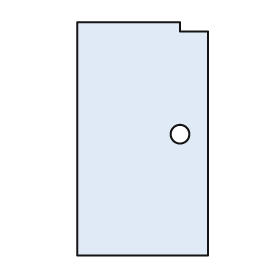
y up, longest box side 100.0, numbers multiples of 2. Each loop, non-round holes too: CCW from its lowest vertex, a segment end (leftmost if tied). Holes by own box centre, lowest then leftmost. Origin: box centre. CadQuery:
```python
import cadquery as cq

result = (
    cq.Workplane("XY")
    .moveTo(-28.0, -50.0)
    .lineTo(28.0, -50.0)
    .lineTo(28.0, 46.0)
    .lineTo(16.0, 46.0)
    .lineTo(16.0, 50.0)
    .lineTo(-28.0, 50.0)
    .close()
    .moveTo(16.0, 2.0)
    .circle(4.0)
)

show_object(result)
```